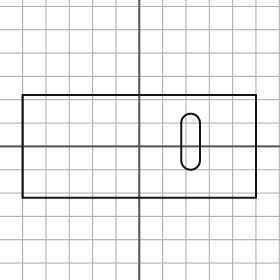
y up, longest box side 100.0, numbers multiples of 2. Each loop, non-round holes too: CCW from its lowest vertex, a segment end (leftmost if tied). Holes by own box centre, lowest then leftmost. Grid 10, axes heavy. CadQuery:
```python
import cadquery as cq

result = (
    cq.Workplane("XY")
    .moveTo(-50.0, -22.0)
    .lineTo(50.0, -22.0)
    .lineTo(50.0, 22.0)
    .lineTo(-50.0, 22.0)
    .close()
    .moveTo(18.0, -6.0)
    .threePointArc((22.0, -10.0), (26.0, -6.0))
    .lineTo(26.0, 10.0)
    .threePointArc((22.0, 14.0), (18.0, 10.0))
    .close()
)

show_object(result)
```